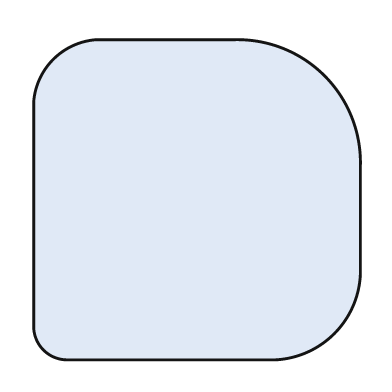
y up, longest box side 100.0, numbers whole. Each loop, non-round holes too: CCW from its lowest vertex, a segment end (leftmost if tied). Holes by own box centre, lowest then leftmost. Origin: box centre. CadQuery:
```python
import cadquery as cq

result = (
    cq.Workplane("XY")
    .moveTo(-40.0, -49.0)
    .lineTo(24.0, -49.0)
    .threePointArc((42.0, -41.0), (50.0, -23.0))
    .lineTo(50.0, 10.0)
    .threePointArc((39.0, 38.0), (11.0, 49.0))
    .lineTo(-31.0, 49.0)
    .threePointArc((-44.0, 43.0), (-50.0, 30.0))
    .lineTo(-50.0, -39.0)
    .threePointArc((-47.0, -46.0), (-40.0, -49.0))
    .close()
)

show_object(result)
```